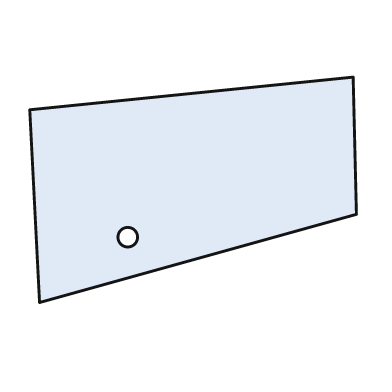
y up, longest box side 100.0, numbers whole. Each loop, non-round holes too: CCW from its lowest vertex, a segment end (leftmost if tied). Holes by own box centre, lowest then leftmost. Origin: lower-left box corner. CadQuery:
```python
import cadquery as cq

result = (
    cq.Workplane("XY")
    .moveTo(3.0, 0.0)
    .lineTo(100.0, 27.0)
    .lineTo(99.0, 69.0)
    .lineTo(0.0, 59.0)
    .close()
    .moveTo(30.0, 20.0)
    .circle(3.0)
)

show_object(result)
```